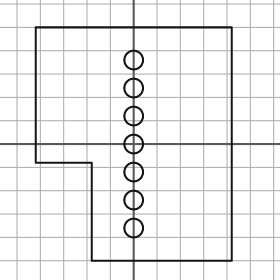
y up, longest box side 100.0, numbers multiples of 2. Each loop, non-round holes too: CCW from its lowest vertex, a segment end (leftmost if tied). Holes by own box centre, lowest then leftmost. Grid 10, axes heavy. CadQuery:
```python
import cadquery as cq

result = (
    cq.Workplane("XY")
    .moveTo(-18.0, -50.0)
    .lineTo(42.0, -50.0)
    .lineTo(42.0, 50.0)
    .lineTo(-42.0, 50.0)
    .lineTo(-42.0, -8.0)
    .lineTo(-18.0, -8.0)
    .close()
    .moveTo(0.0, -36.0)
    .circle(4.0)
    .moveTo(0.0, -24.0)
    .circle(4.0)
    .moveTo(0.0, -12.0)
    .circle(4.0)
    .moveTo(0.0, 0.0)
    .circle(4.0)
    .moveTo(0.0, 12.0)
    .circle(4.0)
    .moveTo(0.0, 24.0)
    .circle(4.0)
    .moveTo(0.0, 36.0)
    .circle(4.0)
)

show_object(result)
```